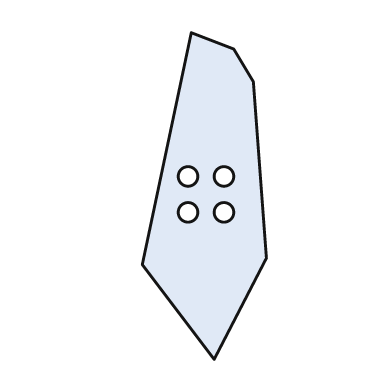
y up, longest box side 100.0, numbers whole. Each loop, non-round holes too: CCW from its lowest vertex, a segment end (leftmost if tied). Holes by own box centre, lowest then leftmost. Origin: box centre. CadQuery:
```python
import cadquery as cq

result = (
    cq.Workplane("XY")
    .moveTo(3.0, -50.0)
    .lineTo(19.0, -19.0)
    .lineTo(15.0, 35.0)
    .lineTo(9.0, 45.0)
    .lineTo(-4.0, 50.0)
    .lineTo(-19.0, -21.0)
    .close()
    .moveTo(-5.0, -5.0)
    .circle(3.0)
    .moveTo(6.0, -5.0)
    .circle(3.0)
    .moveTo(-5.0, 6.0)
    .circle(3.0)
    .moveTo(6.0, 6.0)
    .circle(3.0)
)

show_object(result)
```